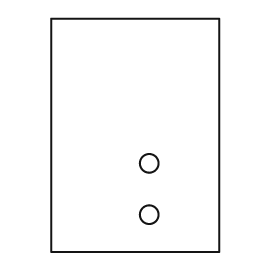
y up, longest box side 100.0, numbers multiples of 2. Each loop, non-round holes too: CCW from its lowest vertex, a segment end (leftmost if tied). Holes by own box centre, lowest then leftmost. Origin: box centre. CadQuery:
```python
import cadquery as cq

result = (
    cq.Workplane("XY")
    .moveTo(-36.0, -50.0)
    .lineTo(36.0, -50.0)
    .lineTo(36.0, 50.0)
    .lineTo(-36.0, 50.0)
    .close()
    .moveTo(6.0, -34.0)
    .circle(4.0)
    .moveTo(6.0, -12.0)
    .circle(4.0)
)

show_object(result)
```